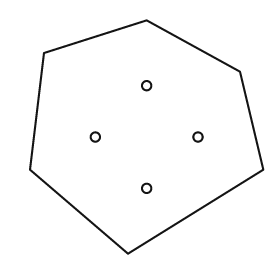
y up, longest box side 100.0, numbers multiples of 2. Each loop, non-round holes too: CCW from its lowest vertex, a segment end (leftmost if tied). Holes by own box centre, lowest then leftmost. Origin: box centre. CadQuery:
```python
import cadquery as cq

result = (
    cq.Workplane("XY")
    .moveTo(-8.0, -50.0)
    .lineTo(50.0, -14.0)
    .lineTo(40.0, 28.0)
    .lineTo(0.0, 50.0)
    .lineTo(-44.0, 36.0)
    .lineTo(-50.0, -14.0)
    .close()
    .moveTo(0.0, -22.0)
    .circle(2.0)
    .moveTo(-22.0, 0.0)
    .circle(2.0)
    .moveTo(22.0, 0.0)
    .circle(2.0)
    .moveTo(0.0, 22.0)
    .circle(2.0)
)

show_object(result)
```